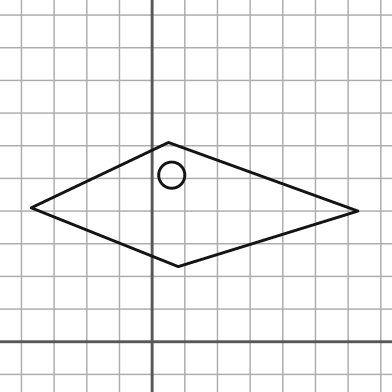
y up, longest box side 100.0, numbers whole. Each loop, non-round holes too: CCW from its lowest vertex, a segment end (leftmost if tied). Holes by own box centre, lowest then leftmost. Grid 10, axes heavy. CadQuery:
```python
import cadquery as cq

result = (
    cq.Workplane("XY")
    .moveTo(8.0, 23.0)
    .lineTo(63.0, 40.0)
    .lineTo(5.0, 61.0)
    .lineTo(-37.0, 41.0)
    .close()
    .moveTo(6.0, 51.0)
    .circle(4.0)
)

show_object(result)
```